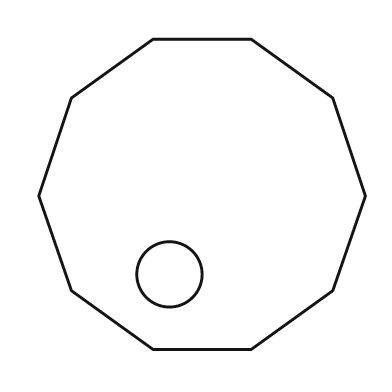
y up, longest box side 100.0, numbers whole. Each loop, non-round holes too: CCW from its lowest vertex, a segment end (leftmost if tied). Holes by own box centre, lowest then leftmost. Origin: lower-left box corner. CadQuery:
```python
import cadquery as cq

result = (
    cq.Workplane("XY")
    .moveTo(35.0, 0.0)
    .lineTo(65.0, 0.0)
    .lineTo(90.0, 18.0)
    .lineTo(100.0, 47.0)
    .lineTo(90.0, 77.0)
    .lineTo(65.0, 95.0)
    .lineTo(35.0, 95.0)
    .lineTo(10.0, 77.0)
    .lineTo(0.0, 47.0)
    .lineTo(10.0, 18.0)
    .close()
    .moveTo(40.0, 23.0)
    .circle(10.0)
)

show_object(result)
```